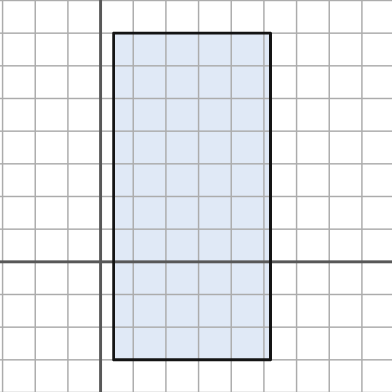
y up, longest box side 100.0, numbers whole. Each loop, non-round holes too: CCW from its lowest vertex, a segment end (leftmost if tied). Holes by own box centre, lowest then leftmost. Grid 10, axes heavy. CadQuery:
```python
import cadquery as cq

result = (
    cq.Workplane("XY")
    .moveTo(4.0, -30.0)
    .lineTo(52.0, -30.0)
    .lineTo(52.0, 70.0)
    .lineTo(4.0, 70.0)
    .close()
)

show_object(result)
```